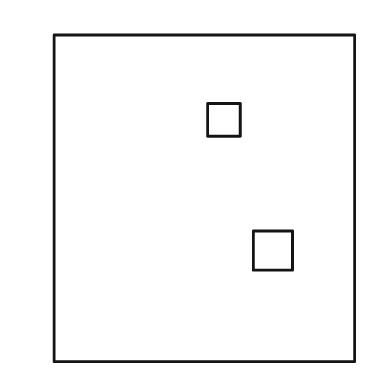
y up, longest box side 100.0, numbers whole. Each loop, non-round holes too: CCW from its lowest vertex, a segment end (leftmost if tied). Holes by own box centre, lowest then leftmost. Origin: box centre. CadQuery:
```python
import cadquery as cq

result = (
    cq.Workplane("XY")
    .moveTo(-46.0, -50.0)
    .lineTo(46.0, -50.0)
    .lineTo(46.0, 50.0)
    .lineTo(-46.0, 50.0)
    .close()
    .moveTo(15.0, -22.0)
    .lineTo(27.0, -22.0)
    .lineTo(27.0, -10.0)
    .lineTo(15.0, -10.0)
    .close()
    .moveTo(1.0, 19.0)
    .lineTo(11.0, 19.0)
    .lineTo(11.0, 29.0)
    .lineTo(1.0, 29.0)
    .close()
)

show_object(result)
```